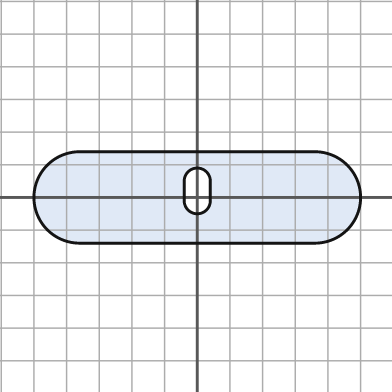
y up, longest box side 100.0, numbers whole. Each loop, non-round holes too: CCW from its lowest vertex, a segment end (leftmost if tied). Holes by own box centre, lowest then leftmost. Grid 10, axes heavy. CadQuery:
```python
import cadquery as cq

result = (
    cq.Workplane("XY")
    .moveTo(-36.0, -14.0)
    .lineTo(36.0, -14.0)
    .threePointArc((50.0, 0.0), (36.0, 14.0))
    .lineTo(-36.0, 14.0)
    .threePointArc((-50.0, 0.0), (-36.0, -14.0))
    .close()
    .moveTo(-4.0, -1.0)
    .threePointArc((0.0, -5.0), (4.0, -1.0))
    .lineTo(4.0, 5.0)
    .threePointArc((0.0, 9.0), (-4.0, 5.0))
    .close()
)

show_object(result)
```